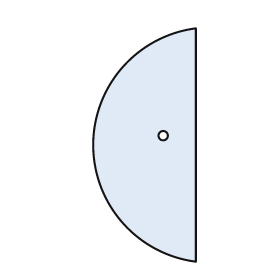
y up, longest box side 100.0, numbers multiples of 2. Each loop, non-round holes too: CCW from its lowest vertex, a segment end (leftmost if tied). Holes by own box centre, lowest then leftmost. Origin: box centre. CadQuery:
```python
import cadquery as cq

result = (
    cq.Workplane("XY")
    .moveTo(22.0, -50.0)
    .lineTo(22.0, 50.0)
    .threePointArc((-22.0, 0.0), (22.0, -50.0))
    .close()
    .moveTo(8.0, 4.0)
    .circle(2.0)
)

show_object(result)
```